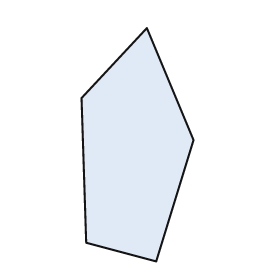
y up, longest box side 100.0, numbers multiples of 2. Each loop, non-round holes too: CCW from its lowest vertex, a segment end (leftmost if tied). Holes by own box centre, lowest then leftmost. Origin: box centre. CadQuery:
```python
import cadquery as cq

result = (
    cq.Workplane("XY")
    .moveTo(8.0, -50.0)
    .lineTo(24.0, 2.0)
    .lineTo(4.0, 50.0)
    .lineTo(-24.0, 20.0)
    .lineTo(-22.0, -42.0)
    .close()
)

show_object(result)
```